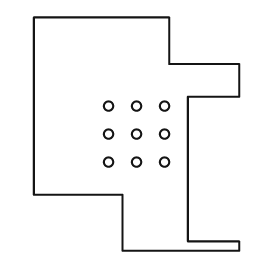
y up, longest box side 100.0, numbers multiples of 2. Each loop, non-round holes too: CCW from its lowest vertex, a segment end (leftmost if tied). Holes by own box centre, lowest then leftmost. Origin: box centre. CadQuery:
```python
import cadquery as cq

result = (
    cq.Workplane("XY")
    .moveTo(-6.0, -50.0)
    .lineTo(44.0, -50.0)
    .lineTo(44.0, -46.0)
    .lineTo(22.0, -46.0)
    .lineTo(22.0, 16.0)
    .lineTo(44.0, 16.0)
    .lineTo(44.0, 30.0)
    .lineTo(14.0, 30.0)
    .lineTo(14.0, 50.0)
    .lineTo(-44.0, 50.0)
    .lineTo(-44.0, -26.0)
    .lineTo(-6.0, -26.0)
    .close()
    .moveTo(-12.0, -12.0)
    .circle(2.0)
    .moveTo(0.0, -12.0)
    .circle(2.0)
    .moveTo(12.0, -12.0)
    .circle(2.0)
    .moveTo(-12.0, 0.0)
    .circle(2.0)
    .moveTo(0.0, 0.0)
    .circle(2.0)
    .moveTo(12.0, 0.0)
    .circle(2.0)
    .moveTo(-12.0, 12.0)
    .circle(2.0)
    .moveTo(0.0, 12.0)
    .circle(2.0)
    .moveTo(12.0, 12.0)
    .circle(2.0)
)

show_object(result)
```